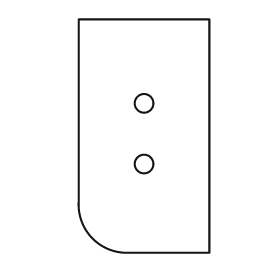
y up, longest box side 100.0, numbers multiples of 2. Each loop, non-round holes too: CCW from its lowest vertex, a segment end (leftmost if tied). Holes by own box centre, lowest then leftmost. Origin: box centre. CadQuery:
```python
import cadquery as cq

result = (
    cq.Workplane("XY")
    .moveTo(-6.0, -50.0)
    .lineTo(28.0, -50.0)
    .lineTo(28.0, 50.0)
    .lineTo(-28.0, 50.0)
    .lineTo(-28.0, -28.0)
    .threePointArc((-22.0, -44.0), (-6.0, -50.0))
    .close()
    .moveTo(0.0, -12.0)
    .circle(4.0)
    .moveTo(0.0, 14.0)
    .circle(4.0)
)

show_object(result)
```